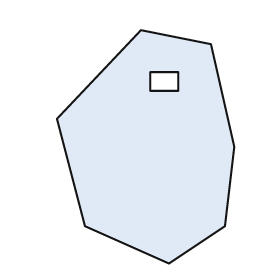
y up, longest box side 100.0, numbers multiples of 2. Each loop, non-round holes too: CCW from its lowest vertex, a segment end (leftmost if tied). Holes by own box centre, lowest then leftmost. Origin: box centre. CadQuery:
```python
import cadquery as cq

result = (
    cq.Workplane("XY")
    .moveTo(10.0, -50.0)
    .lineTo(34.0, -34.0)
    .lineTo(38.0, 0.0)
    .lineTo(28.0, 44.0)
    .lineTo(-2.0, 50.0)
    .lineTo(-38.0, 12.0)
    .lineTo(-26.0, -34.0)
    .close()
    .moveTo(2.0, 24.0)
    .lineTo(14.0, 24.0)
    .lineTo(14.0, 32.0)
    .lineTo(2.0, 32.0)
    .close()
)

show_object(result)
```